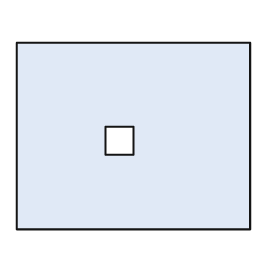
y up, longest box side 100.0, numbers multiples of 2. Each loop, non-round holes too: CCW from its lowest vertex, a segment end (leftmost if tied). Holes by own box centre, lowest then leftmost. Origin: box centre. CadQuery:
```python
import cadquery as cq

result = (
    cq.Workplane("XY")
    .moveTo(-50.0, -40.0)
    .lineTo(50.0, -40.0)
    .lineTo(50.0, 40.0)
    .lineTo(-50.0, 40.0)
    .close()
    .moveTo(-12.0, -8.0)
    .lineTo(0.0, -8.0)
    .lineTo(0.0, 4.0)
    .lineTo(-12.0, 4.0)
    .close()
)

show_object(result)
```